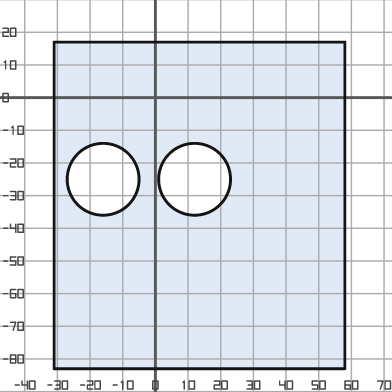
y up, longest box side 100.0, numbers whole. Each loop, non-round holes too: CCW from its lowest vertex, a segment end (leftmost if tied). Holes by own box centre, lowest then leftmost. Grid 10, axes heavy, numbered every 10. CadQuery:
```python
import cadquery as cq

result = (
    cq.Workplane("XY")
    .moveTo(-31.0, -83.0)
    .lineTo(58.0, -83.0)
    .lineTo(58.0, 17.0)
    .lineTo(-31.0, 17.0)
    .close()
    .moveTo(-16.0, -25.0)
    .circle(11.0)
    .moveTo(12.0, -25.0)
    .circle(11.0)
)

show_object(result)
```